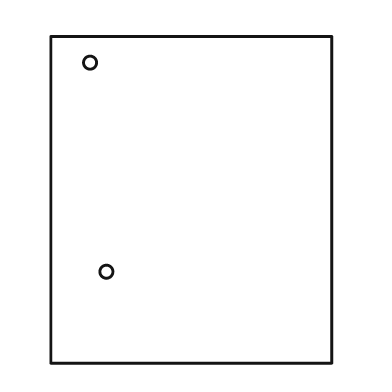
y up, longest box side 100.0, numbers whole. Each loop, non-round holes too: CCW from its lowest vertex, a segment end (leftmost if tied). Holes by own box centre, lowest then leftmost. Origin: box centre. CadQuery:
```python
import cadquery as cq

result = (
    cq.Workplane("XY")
    .moveTo(-43.0, -50.0)
    .lineTo(43.0, -50.0)
    .lineTo(43.0, 50.0)
    .lineTo(-43.0, 50.0)
    .close()
    .moveTo(-26.0, -22.0)
    .circle(2.0)
    .moveTo(-31.0, 42.0)
    .circle(2.0)
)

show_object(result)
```